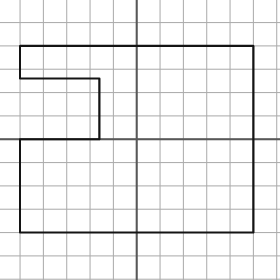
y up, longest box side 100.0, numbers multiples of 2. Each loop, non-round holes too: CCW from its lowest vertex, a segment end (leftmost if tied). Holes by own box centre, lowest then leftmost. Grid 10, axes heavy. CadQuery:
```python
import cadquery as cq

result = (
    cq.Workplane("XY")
    .moveTo(-50.0, -40.0)
    .lineTo(50.0, -40.0)
    .lineTo(50.0, 40.0)
    .lineTo(-50.0, 40.0)
    .lineTo(-50.0, 26.0)
    .lineTo(-16.0, 26.0)
    .lineTo(-16.0, 0.0)
    .lineTo(-50.0, 0.0)
    .close()
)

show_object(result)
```